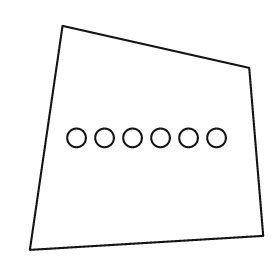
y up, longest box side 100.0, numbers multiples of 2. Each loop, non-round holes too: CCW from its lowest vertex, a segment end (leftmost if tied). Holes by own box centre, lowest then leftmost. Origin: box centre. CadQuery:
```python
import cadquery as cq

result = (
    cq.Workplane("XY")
    .moveTo(-50.0, -48.0)
    .lineTo(50.0, -42.0)
    .lineTo(44.0, 30.0)
    .lineTo(-36.0, 48.0)
    .close()
    .moveTo(-30.0, 0.0)
    .circle(4.0)
    .moveTo(-18.0, 0.0)
    .circle(4.0)
    .moveTo(-6.0, 0.0)
    .circle(4.0)
    .moveTo(6.0, 0.0)
    .circle(4.0)
    .moveTo(18.0, 0.0)
    .circle(4.0)
    .moveTo(30.0, 0.0)
    .circle(4.0)
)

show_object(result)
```